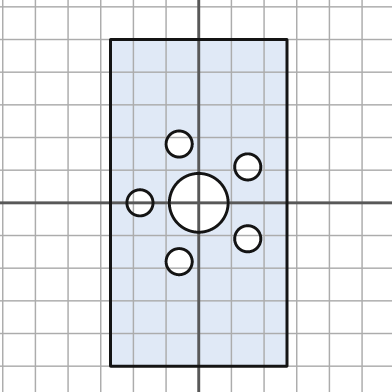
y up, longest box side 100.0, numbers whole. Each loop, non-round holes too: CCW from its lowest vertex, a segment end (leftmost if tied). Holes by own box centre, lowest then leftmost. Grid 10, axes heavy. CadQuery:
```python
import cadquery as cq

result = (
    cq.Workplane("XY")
    .moveTo(-27.0, -50.0)
    .lineTo(27.0, -50.0)
    .lineTo(27.0, 50.0)
    .lineTo(-27.0, 50.0)
    .close()
    .moveTo(-6.0, -18.0)
    .circle(4.0)
    .moveTo(15.0, -11.0)
    .circle(4.0)
    .moveTo(-18.0, 0.0)
    .circle(4.0)
    .moveTo(0.0, 0.0)
    .circle(9.0)
    .moveTo(15.0, 11.0)
    .circle(4.0)
    .moveTo(-6.0, 18.0)
    .circle(4.0)
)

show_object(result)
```